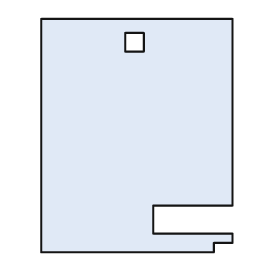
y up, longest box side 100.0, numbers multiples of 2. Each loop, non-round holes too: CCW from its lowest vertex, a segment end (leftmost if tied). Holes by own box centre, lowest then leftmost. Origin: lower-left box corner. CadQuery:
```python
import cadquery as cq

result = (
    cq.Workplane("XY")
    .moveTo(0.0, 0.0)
    .lineTo(74.0, 0.0)
    .lineTo(74.0, 4.0)
    .lineTo(82.0, 4.0)
    .lineTo(82.0, 8.0)
    .lineTo(48.0, 8.0)
    .lineTo(48.0, 20.0)
    .lineTo(82.0, 20.0)
    .lineTo(82.0, 100.0)
    .lineTo(0.0, 100.0)
    .close()
    .moveTo(36.0, 86.0)
    .lineTo(44.0, 86.0)
    .lineTo(44.0, 94.0)
    .lineTo(36.0, 94.0)
    .close()
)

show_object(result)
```